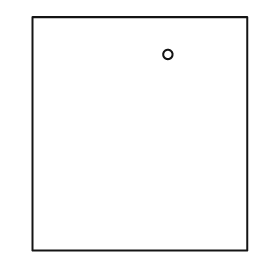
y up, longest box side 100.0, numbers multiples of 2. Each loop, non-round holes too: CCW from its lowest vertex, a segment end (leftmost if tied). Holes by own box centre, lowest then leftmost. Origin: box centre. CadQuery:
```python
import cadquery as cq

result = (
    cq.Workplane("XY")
    .moveTo(-46.0, -50.0)
    .lineTo(46.0, -50.0)
    .lineTo(46.0, 50.0)
    .lineTo(-46.0, 50.0)
    .close()
    .moveTo(12.0, 34.0)
    .circle(2.0)
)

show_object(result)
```